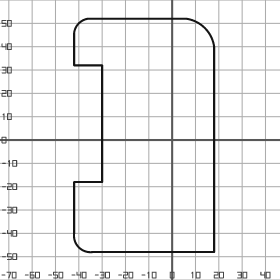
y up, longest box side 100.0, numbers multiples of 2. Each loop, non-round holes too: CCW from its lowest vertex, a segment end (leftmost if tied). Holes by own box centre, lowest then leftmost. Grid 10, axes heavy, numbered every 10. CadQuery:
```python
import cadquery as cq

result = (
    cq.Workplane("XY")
    .moveTo(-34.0, -48.0)
    .lineTo(18.0, -48.0)
    .lineTo(18.0, 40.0)
    .threePointArc((14.0, 48.0), (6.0, 52.0))
    .lineTo(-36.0, 52.0)
    .threePointArc((-40.0, 50.0), (-42.0, 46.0))
    .lineTo(-42.0, 32.0)
    .lineTo(-30.0, 32.0)
    .lineTo(-30.0, -18.0)
    .lineTo(-42.0, -18.0)
    .lineTo(-42.0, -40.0)
    .threePointArc((-40.0, -46.0), (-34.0, -48.0))
    .close()
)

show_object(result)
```